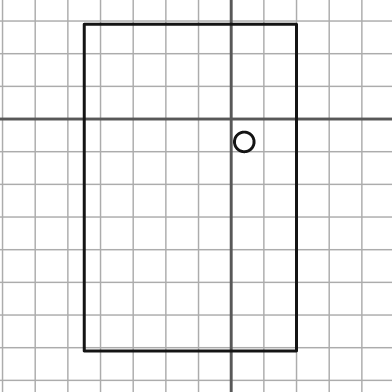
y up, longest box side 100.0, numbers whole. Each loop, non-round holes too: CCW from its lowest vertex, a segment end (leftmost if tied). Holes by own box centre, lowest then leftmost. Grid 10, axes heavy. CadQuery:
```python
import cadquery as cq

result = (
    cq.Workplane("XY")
    .moveTo(-45.0, -71.0)
    .lineTo(20.0, -71.0)
    .lineTo(20.0, 29.0)
    .lineTo(-45.0, 29.0)
    .close()
    .moveTo(4.0, -7.0)
    .circle(3.0)
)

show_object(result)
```